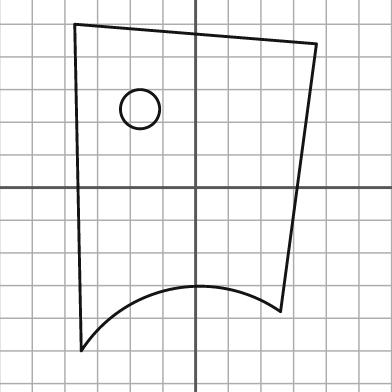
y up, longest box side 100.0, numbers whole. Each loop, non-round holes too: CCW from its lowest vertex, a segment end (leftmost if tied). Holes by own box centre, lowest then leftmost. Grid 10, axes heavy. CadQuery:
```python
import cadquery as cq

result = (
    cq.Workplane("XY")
    .moveTo(-35.0, -50.0)
    .threePointArc((-7.0, -31.0), (26.0, -38.0))
    .lineTo(37.0, 44.0)
    .lineTo(-37.0, 50.0)
    .close()
    .moveTo(-17.0, 24.0)
    .circle(6.0)
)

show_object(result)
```